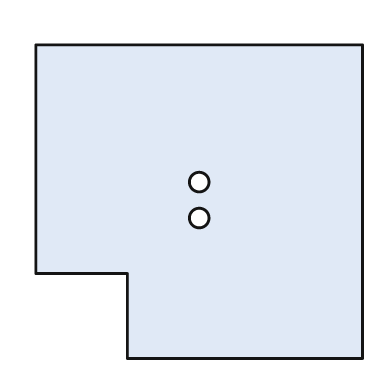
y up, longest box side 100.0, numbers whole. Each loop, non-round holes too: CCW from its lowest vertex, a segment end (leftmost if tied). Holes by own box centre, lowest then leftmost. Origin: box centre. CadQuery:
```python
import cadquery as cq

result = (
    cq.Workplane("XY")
    .moveTo(-22.0, -48.0)
    .lineTo(50.0, -48.0)
    .lineTo(50.0, 48.0)
    .lineTo(-50.0, 48.0)
    .lineTo(-50.0, -22.0)
    .lineTo(-22.0, -22.0)
    .close()
    .moveTo(0.0, -5.0)
    .circle(3.0)
    .moveTo(0.0, 6.0)
    .circle(3.0)
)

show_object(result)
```